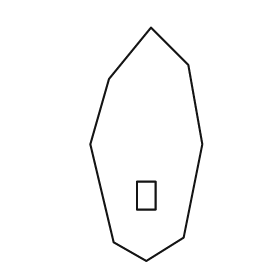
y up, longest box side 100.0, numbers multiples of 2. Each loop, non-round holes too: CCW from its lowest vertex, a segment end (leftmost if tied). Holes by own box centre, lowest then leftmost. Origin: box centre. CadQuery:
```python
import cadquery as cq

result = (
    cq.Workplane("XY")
    .moveTo(0.0, -50.0)
    .lineTo(16.0, -40.0)
    .lineTo(24.0, 0.0)
    .lineTo(18.0, 34.0)
    .lineTo(2.0, 50.0)
    .lineTo(-16.0, 28.0)
    .lineTo(-24.0, 0.0)
    .lineTo(-14.0, -42.0)
    .close()
    .moveTo(-4.0, -28.0)
    .lineTo(4.0, -28.0)
    .lineTo(4.0, -16.0)
    .lineTo(-4.0, -16.0)
    .close()
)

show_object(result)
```